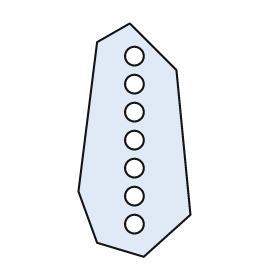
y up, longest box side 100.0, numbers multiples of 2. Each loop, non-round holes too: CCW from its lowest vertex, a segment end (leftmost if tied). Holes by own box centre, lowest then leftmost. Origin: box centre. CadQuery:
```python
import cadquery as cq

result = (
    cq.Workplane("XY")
    .moveTo(4.0, -50.0)
    .lineTo(24.0, -32.0)
    .lineTo(18.0, 30.0)
    .lineTo(-2.0, 50.0)
    .lineTo(-16.0, 42.0)
    .lineTo(-24.0, -22.0)
    .lineTo(-16.0, -44.0)
    .close()
    .moveTo(0.0, -36.0)
    .circle(4.0)
    .moveTo(0.0, -24.0)
    .circle(4.0)
    .moveTo(0.0, -12.0)
    .circle(4.0)
    .moveTo(0.0, 0.0)
    .circle(4.0)
    .moveTo(0.0, 12.0)
    .circle(4.0)
    .moveTo(0.0, 24.0)
    .circle(4.0)
    .moveTo(0.0, 36.0)
    .circle(4.0)
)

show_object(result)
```